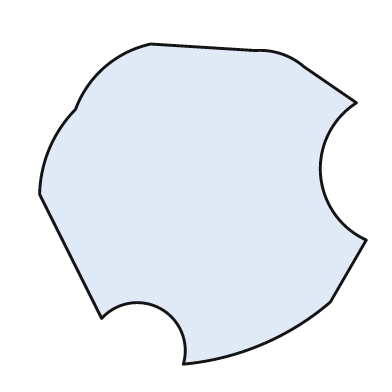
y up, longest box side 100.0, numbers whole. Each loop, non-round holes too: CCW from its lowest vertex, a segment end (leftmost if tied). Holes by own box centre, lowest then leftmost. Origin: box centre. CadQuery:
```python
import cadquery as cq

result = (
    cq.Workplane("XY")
    .moveTo(-6.0, -49.0)
    .threePointArc((18.0, -43.0), (39.0, -30.0))
    .lineTo(50.0, -11.0)
    .threePointArc((36.0, 9.0), (47.0, 31.0))
    .lineTo(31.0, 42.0)
    .threePointArc((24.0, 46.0), (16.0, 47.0))
    .lineTo(-16.0, 49.0)
    .threePointArc((-30.0, 42.0), (-39.0, 29.0))
    .threePointArc((-47.0, 17.0), (-50.0, 3.0))
    .lineTo(-31.0, -35.0)
    .threePointArc((-13.0, -32.0), (-6.0, -49.0))
    .close()
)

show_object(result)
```